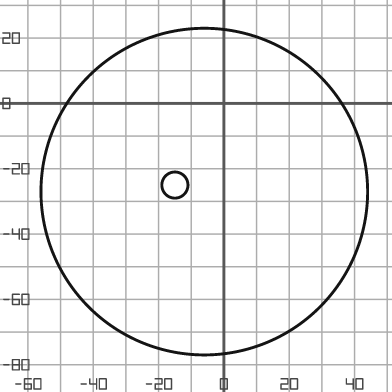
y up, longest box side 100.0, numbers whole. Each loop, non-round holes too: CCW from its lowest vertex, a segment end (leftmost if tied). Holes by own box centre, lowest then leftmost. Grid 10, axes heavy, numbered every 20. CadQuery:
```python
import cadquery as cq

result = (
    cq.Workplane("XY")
    .moveTo(-6.0, -27.0)
    .circle(50.0)
    .moveTo(-15.0, -25.0)
    .circle(4.0)
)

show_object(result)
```